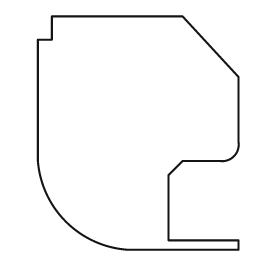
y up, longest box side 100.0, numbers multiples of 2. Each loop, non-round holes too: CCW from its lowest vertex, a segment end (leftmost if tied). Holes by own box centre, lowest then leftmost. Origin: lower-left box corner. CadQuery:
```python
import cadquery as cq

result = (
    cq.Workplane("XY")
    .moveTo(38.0, 0.0)
    .lineTo(86.0, 0.0)
    .lineTo(86.0, 4.0)
    .lineTo(56.0, 4.0)
    .lineTo(56.0, 32.0)
    .lineTo(62.0, 38.0)
    .lineTo(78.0, 38.0)
    .threePointArc((84.0, 40.0), (86.0, 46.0))
    .lineTo(86.0, 74.0)
    .lineTo(62.0, 100.0)
    .lineTo(6.0, 100.0)
    .lineTo(6.0, 90.0)
    .lineTo(0.0, 90.0)
    .lineTo(0.0, 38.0)
    .threePointArc((12.0, 12.0), (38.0, 0.0))
    .close()
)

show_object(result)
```